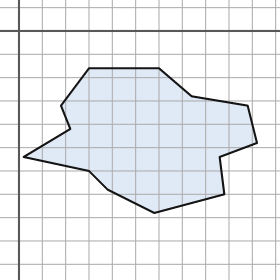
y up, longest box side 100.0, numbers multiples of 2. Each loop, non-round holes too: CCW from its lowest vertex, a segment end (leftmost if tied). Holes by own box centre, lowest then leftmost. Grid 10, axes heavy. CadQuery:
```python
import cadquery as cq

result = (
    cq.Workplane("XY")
    .moveTo(58.0, -78.0)
    .lineTo(88.0, -70.0)
    .lineTo(86.0, -54.0)
    .lineTo(102.0, -48.0)
    .lineTo(98.0, -32.0)
    .lineTo(74.0, -28.0)
    .lineTo(60.0, -16.0)
    .lineTo(30.0, -16.0)
    .lineTo(18.0, -32.0)
    .lineTo(22.0, -42.0)
    .lineTo(2.0, -54.0)
    .lineTo(30.0, -60.0)
    .lineTo(38.0, -68.0)
    .close()
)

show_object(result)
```